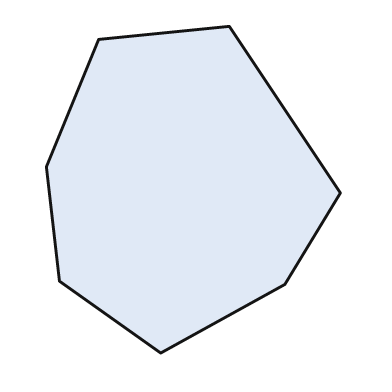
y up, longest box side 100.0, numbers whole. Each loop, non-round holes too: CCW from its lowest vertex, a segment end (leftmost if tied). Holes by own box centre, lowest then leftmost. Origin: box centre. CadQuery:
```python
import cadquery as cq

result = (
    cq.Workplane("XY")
    .moveTo(-10.0, -50.0)
    .lineTo(28.0, -29.0)
    .lineTo(45.0, -1.0)
    .lineTo(11.0, 50.0)
    .lineTo(-29.0, 46.0)
    .lineTo(-45.0, 7.0)
    .lineTo(-41.0, -28.0)
    .close()
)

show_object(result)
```